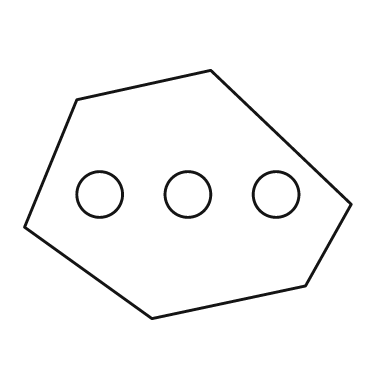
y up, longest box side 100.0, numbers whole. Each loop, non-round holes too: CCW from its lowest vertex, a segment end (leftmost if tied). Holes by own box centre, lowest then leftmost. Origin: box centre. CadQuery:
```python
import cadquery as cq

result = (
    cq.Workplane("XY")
    .moveTo(-11.0, -38.0)
    .lineTo(36.0, -28.0)
    .lineTo(50.0, -3.0)
    .lineTo(7.0, 38.0)
    .lineTo(-34.0, 29.0)
    .lineTo(-50.0, -10.0)
    .close()
    .moveTo(-27.0, 0.0)
    .circle(7.0)
    .moveTo(0.0, 0.0)
    .circle(7.0)
    .moveTo(27.0, 0.0)
    .circle(7.0)
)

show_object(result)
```